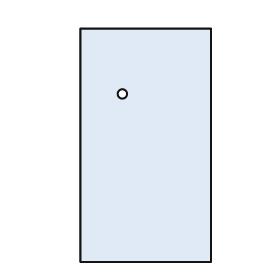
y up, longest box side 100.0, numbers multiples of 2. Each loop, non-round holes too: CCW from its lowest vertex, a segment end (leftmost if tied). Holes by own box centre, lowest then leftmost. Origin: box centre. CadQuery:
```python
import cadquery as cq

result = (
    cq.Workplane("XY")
    .moveTo(-28.0, -50.0)
    .lineTo(28.0, -50.0)
    .lineTo(28.0, 50.0)
    .lineTo(-28.0, 50.0)
    .close()
    .moveTo(-10.0, 22.0)
    .circle(2.0)
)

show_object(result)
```